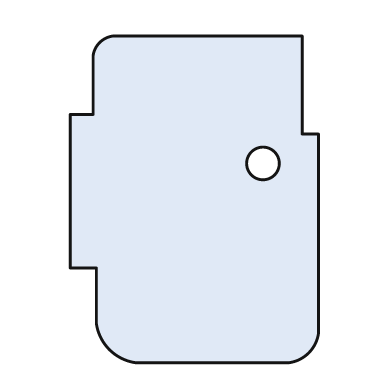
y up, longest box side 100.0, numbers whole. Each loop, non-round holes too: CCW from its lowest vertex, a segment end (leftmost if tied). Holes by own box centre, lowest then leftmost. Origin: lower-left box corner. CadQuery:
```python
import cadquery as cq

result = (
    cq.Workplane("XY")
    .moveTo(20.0, 0.0)
    .lineTo(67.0, 0.0)
    .threePointArc((73.0, 3.0), (76.0, 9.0))
    .lineTo(76.0, 70.0)
    .lineTo(71.0, 70.0)
    .lineTo(71.0, 100.0)
    .lineTo(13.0, 100.0)
    .threePointArc((9.0, 98.0), (7.0, 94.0))
    .lineTo(7.0, 76.0)
    .lineTo(0.0, 76.0)
    .lineTo(0.0, 29.0)
    .lineTo(8.0, 29.0)
    .lineTo(8.0, 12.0)
    .threePointArc((12.0, 4.0), (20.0, 0.0))
    .close()
    .moveTo(59.0, 61.0)
    .circle(5.0)
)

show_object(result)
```